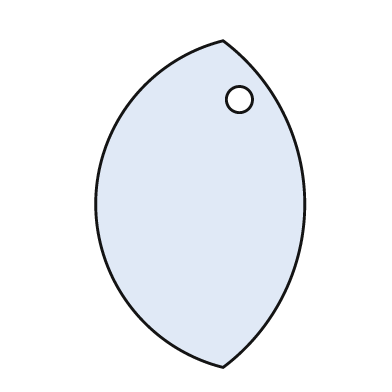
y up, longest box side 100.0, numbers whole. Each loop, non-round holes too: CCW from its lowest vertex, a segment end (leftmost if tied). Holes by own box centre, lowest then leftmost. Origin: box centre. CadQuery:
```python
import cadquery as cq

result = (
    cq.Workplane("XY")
    .moveTo(7.0, -50.0)
    .threePointArc((32.0, 0.0), (7.0, 50.0))
    .threePointArc((-32.0, 0.0), (7.0, -50.0))
    .close()
    .moveTo(12.0, 32.0)
    .circle(4.0)
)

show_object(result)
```